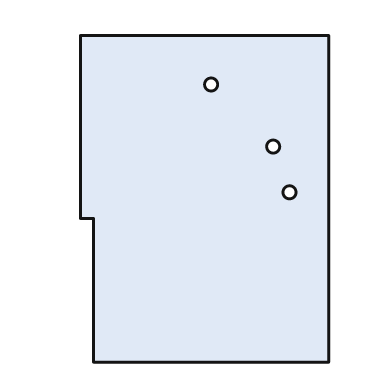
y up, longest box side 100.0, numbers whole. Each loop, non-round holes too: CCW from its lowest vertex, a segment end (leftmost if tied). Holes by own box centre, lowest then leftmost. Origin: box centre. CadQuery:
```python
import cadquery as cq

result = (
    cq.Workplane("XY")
    .moveTo(-34.0, -50.0)
    .lineTo(38.0, -50.0)
    .lineTo(38.0, 50.0)
    .lineTo(-38.0, 50.0)
    .lineTo(-38.0, -6.0)
    .lineTo(-34.0, -6.0)
    .close()
    .moveTo(26.0, 2.0)
    .circle(2.0)
    .moveTo(21.0, 16.0)
    .circle(2.0)
    .moveTo(2.0, 35.0)
    .circle(2.0)
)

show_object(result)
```